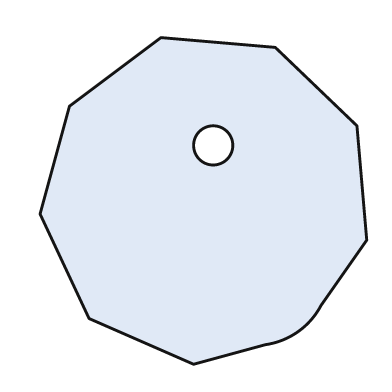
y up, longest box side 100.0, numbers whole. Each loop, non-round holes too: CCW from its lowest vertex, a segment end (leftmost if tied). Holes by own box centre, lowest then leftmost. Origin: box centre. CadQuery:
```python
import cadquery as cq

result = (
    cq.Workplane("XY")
    .moveTo(-3.0, -50.0)
    .lineTo(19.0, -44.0)
    .threePointArc((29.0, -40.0), (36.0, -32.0))
    .lineTo(50.0, -12.0)
    .lineTo(47.0, 23.0)
    .lineTo(22.0, 47.0)
    .lineTo(-13.0, 50.0)
    .lineTo(-41.0, 29.0)
    .lineTo(-50.0, -4.0)
    .lineTo(-35.0, -36.0)
    .close()
    .moveTo(3.0, 17.0)
    .circle(6.0)
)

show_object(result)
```